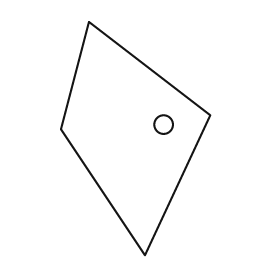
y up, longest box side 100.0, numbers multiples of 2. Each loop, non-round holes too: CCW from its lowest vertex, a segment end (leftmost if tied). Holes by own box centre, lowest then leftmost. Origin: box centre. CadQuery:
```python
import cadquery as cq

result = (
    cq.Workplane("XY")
    .moveTo(4.0, -50.0)
    .lineTo(32.0, 10.0)
    .lineTo(-20.0, 50.0)
    .lineTo(-32.0, 4.0)
    .close()
    .moveTo(12.0, 6.0)
    .circle(4.0)
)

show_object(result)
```